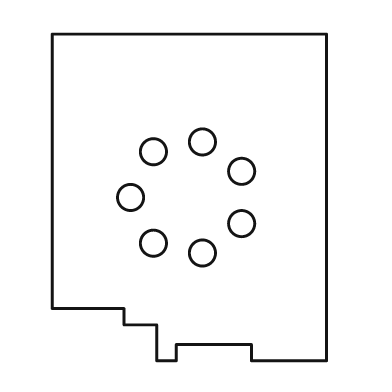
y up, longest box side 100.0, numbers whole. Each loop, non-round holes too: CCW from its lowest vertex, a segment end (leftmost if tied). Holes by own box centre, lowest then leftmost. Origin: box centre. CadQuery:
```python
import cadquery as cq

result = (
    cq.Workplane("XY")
    .moveTo(-10.0, -50.0)
    .lineTo(-4.0, -50.0)
    .lineTo(-4.0, -45.0)
    .lineTo(19.0, -45.0)
    .lineTo(19.0, -50.0)
    .lineTo(42.0, -50.0)
    .lineTo(42.0, 50.0)
    .lineTo(-42.0, 50.0)
    .lineTo(-42.0, -34.0)
    .lineTo(-20.0, -34.0)
    .lineTo(-20.0, -39.0)
    .lineTo(-10.0, -39.0)
    .close()
    .moveTo(4.0, -17.0)
    .circle(4.0)
    .moveTo(-11.0, -14.0)
    .circle(4.0)
    .moveTo(16.0, -8.0)
    .circle(4.0)
    .moveTo(-18.0, 0.0)
    .circle(4.0)
    .moveTo(16.0, 8.0)
    .circle(4.0)
    .moveTo(-11.0, 14.0)
    .circle(4.0)
    .moveTo(4.0, 17.0)
    .circle(4.0)
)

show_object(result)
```